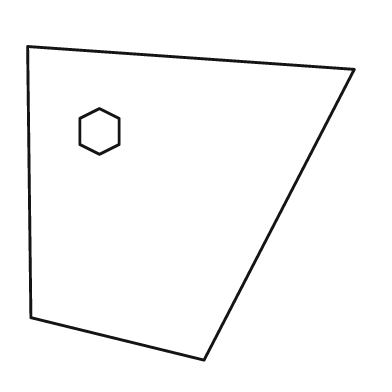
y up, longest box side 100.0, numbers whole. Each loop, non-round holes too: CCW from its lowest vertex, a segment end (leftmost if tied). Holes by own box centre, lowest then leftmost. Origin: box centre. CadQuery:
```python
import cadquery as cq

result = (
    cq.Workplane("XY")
    .moveTo(4.0, -48.0)
    .lineTo(50.0, 41.0)
    .lineTo(-50.0, 48.0)
    .lineTo(-49.0, -35.0)
    .close()
    .moveTo(-28.0, 15.0)
    .lineTo(-22.0, 18.0)
    .lineTo(-22.0, 26.0)
    .lineTo(-28.0, 29.0)
    .lineTo(-34.0, 26.0)
    .lineTo(-34.0, 18.0)
    .close()
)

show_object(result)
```